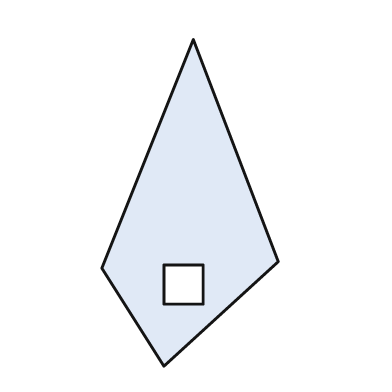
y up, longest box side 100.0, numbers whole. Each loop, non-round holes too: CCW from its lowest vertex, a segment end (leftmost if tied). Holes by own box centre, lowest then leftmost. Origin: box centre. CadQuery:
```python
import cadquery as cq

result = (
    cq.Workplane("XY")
    .moveTo(-8.0, -50.0)
    .lineTo(27.0, -18.0)
    .lineTo(1.0, 50.0)
    .lineTo(-27.0, -20.0)
    .close()
    .moveTo(-8.0, -31.0)
    .lineTo(4.0, -31.0)
    .lineTo(4.0, -19.0)
    .lineTo(-8.0, -19.0)
    .close()
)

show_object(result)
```